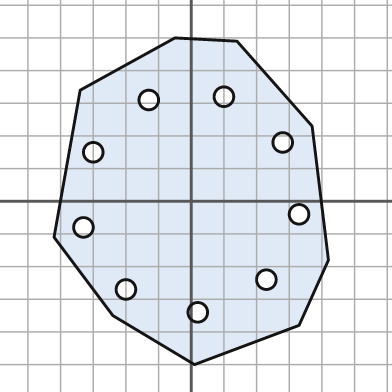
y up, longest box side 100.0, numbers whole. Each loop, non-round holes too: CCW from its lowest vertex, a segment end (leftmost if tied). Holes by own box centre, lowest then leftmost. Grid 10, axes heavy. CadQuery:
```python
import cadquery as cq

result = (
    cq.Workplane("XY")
    .moveTo(1.0, -50.0)
    .lineTo(33.0, -38.0)
    .lineTo(42.0, -18.0)
    .lineTo(37.0, 23.0)
    .lineTo(14.0, 49.0)
    .lineTo(-5.0, 50.0)
    .lineTo(-34.0, 34.0)
    .lineTo(-42.0, -11.0)
    .lineTo(-24.0, -35.0)
    .close()
    .moveTo(2.0, -34.0)
    .circle(3.0)
    .moveTo(-20.0, -27.0)
    .circle(3.0)
    .moveTo(23.0, -24.0)
    .circle(3.0)
    .moveTo(-33.0, -8.0)
    .circle(3.0)
    .moveTo(33.0, -4.0)
    .circle(3.0)
    .moveTo(-30.0, 15.0)
    .circle(3.0)
    .moveTo(28.0, 18.0)
    .circle(3.0)
    .moveTo(-13.0, 31.0)
    .circle(3.0)
    .moveTo(10.0, 32.0)
    .circle(3.0)
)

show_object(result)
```